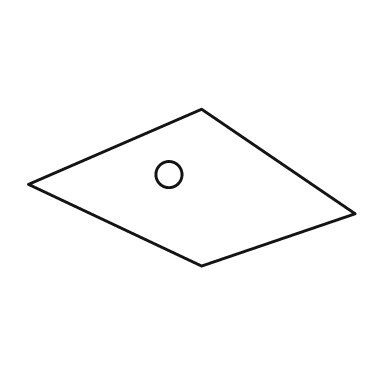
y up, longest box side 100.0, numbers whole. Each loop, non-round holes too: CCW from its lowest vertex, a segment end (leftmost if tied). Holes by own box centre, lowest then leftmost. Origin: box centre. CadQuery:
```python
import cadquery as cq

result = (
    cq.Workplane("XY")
    .moveTo(3.0, -24.0)
    .lineTo(50.0, -8.0)
    .lineTo(3.0, 24.0)
    .lineTo(-50.0, 1.0)
    .close()
    .moveTo(-7.0, 4.0)
    .circle(4.0)
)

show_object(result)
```